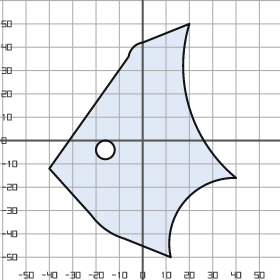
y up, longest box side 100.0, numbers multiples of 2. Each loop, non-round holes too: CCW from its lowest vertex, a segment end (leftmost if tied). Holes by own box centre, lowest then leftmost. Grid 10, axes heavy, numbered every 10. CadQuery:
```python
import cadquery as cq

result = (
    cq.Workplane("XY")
    .moveTo(12.0, -50.0)
    .threePointArc((18.0, -26.0), (40.0, -16.0))
    .threePointArc((20.0, 14.0), (20.0, 50.0))
    .lineTo(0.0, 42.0)
    .threePointArc((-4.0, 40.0), (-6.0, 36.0))
    .lineTo(-40.0, -12.0)
    .lineTo(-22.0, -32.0)
    .threePointArc((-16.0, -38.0), (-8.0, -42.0))
    .close()
    .moveTo(-16.0, -4.0)
    .circle(4.0)
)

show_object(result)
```